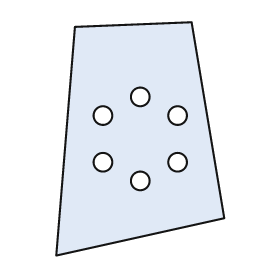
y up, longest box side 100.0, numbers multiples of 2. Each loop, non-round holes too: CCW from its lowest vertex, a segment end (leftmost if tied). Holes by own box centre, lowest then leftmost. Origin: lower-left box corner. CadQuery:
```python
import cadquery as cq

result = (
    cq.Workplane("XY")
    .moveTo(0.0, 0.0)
    .lineTo(72.0, 16.0)
    .lineTo(58.0, 100.0)
    .lineTo(8.0, 98.0)
    .close()
    .moveTo(36.0, 32.0)
    .circle(4.0)
    .moveTo(20.0, 40.0)
    .circle(4.0)
    .moveTo(52.0, 40.0)
    .circle(4.0)
    .moveTo(20.0, 60.0)
    .circle(4.0)
    .moveTo(52.0, 60.0)
    .circle(4.0)
    .moveTo(36.0, 68.0)
    .circle(4.0)
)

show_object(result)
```